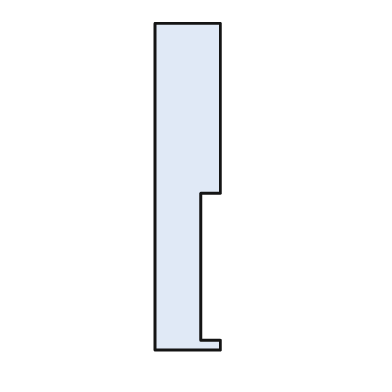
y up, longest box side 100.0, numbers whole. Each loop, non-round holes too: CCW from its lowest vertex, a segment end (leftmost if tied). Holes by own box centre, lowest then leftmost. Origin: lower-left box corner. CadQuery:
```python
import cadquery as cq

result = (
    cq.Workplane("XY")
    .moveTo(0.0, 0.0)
    .lineTo(20.0, 0.0)
    .lineTo(20.0, 3.0)
    .lineTo(14.0, 3.0)
    .lineTo(14.0, 48.0)
    .lineTo(20.0, 48.0)
    .lineTo(20.0, 100.0)
    .lineTo(0.0, 100.0)
    .close()
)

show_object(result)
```